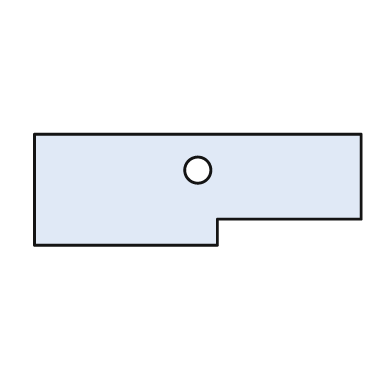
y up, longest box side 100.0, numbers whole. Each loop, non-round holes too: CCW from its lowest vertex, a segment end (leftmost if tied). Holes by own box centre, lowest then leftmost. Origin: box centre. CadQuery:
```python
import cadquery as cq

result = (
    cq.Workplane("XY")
    .moveTo(-50.0, -17.0)
    .lineTo(6.0, -17.0)
    .lineTo(6.0, -9.0)
    .lineTo(50.0, -9.0)
    .lineTo(50.0, 17.0)
    .lineTo(-50.0, 17.0)
    .close()
    .moveTo(0.0, 6.0)
    .circle(4.0)
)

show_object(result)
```